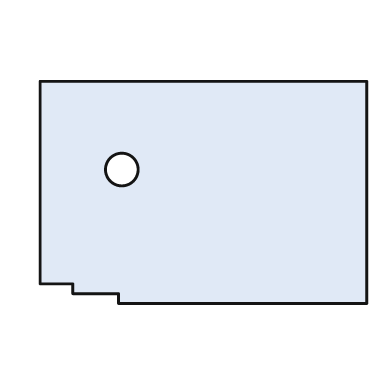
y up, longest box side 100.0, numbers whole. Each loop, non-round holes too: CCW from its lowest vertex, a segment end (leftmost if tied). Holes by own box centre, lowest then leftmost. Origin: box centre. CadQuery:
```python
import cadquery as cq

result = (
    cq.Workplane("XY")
    .moveTo(-26.0, -34.0)
    .lineTo(50.0, -34.0)
    .lineTo(50.0, 34.0)
    .lineTo(-50.0, 34.0)
    .lineTo(-50.0, -28.0)
    .lineTo(-40.0, -28.0)
    .lineTo(-40.0, -31.0)
    .lineTo(-26.0, -31.0)
    .close()
    .moveTo(-25.0, 7.0)
    .circle(5.0)
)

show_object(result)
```